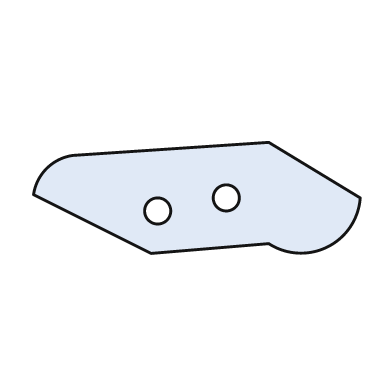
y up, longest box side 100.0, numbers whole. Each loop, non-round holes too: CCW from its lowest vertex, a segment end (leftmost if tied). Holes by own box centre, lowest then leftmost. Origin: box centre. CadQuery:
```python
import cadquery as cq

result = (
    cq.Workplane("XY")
    .moveTo(-14.0, -17.0)
    .lineTo(22.0, -14.0)
    .threePointArc((40.0, -15.0), (50.0, 0.0))
    .lineTo(22.0, 17.0)
    .lineTo(-38.0, 13.0)
    .threePointArc((-46.0, 9.0), (-50.0, 1.0))
    .close()
    .moveTo(-12.0, -4.0)
    .circle(4.0)
    .moveTo(9.0, 0.0)
    .circle(4.0)
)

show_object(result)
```